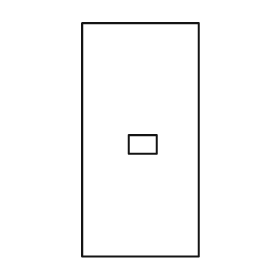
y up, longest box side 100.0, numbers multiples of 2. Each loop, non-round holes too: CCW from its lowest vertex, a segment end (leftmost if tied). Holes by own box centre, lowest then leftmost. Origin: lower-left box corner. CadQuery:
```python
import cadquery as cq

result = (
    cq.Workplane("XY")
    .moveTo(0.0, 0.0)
    .lineTo(50.0, 0.0)
    .lineTo(50.0, 100.0)
    .lineTo(0.0, 100.0)
    .close()
    .moveTo(20.0, 44.0)
    .lineTo(32.0, 44.0)
    .lineTo(32.0, 52.0)
    .lineTo(20.0, 52.0)
    .close()
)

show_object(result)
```